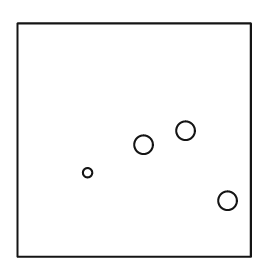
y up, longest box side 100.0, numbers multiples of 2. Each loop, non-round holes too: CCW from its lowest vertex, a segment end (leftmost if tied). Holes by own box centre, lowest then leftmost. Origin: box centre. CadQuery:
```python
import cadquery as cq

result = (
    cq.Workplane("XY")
    .moveTo(-50.0, -50.0)
    .lineTo(50.0, -50.0)
    .lineTo(50.0, 50.0)
    .lineTo(-50.0, 50.0)
    .close()
    .moveTo(40.0, -26.0)
    .circle(4.0)
    .moveTo(-20.0, -14.0)
    .circle(2.0)
    .moveTo(4.0, -2.0)
    .circle(4.0)
    .moveTo(22.0, 4.0)
    .circle(4.0)
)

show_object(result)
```